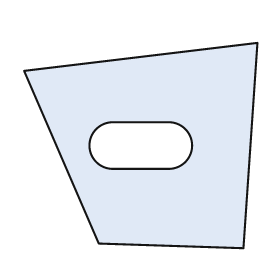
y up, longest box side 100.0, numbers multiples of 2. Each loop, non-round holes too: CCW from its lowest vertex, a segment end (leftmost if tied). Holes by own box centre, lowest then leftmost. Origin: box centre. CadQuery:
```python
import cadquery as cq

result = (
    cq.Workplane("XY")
    .moveTo(44.0, -44.0)
    .lineTo(50.0, 44.0)
    .lineTo(-50.0, 32.0)
    .lineTo(-18.0, -42.0)
    .close()
    .moveTo(-12.0, -10.0)
    .lineTo(12.0, -10.0)
    .threePointArc((22.0, 0.0), (12.0, 10.0))
    .lineTo(-12.0, 10.0)
    .threePointArc((-22.0, 0.0), (-12.0, -10.0))
    .close()
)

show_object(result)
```